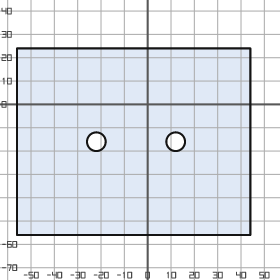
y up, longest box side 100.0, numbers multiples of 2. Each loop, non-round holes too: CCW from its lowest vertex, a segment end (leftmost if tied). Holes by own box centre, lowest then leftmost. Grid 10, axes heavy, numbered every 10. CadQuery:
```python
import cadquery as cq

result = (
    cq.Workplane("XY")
    .moveTo(-56.0, -56.0)
    .lineTo(44.0, -56.0)
    .lineTo(44.0, 24.0)
    .lineTo(-56.0, 24.0)
    .close()
    .moveTo(-22.0, -16.0)
    .circle(4.0)
    .moveTo(12.0, -16.0)
    .circle(4.0)
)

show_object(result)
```